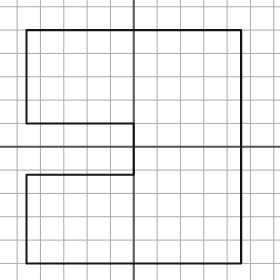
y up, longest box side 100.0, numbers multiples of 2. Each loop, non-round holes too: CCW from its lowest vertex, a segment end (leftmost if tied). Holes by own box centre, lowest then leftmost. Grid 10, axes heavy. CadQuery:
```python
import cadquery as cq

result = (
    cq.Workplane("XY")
    .moveTo(-46.0, -50.0)
    .lineTo(46.0, -50.0)
    .lineTo(46.0, 50.0)
    .lineTo(-46.0, 50.0)
    .lineTo(-46.0, 10.0)
    .lineTo(0.0, 10.0)
    .lineTo(0.0, -12.0)
    .lineTo(-46.0, -12.0)
    .close()
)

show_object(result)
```